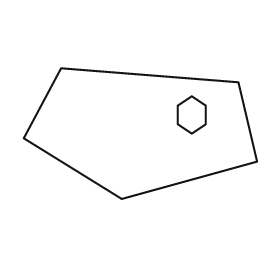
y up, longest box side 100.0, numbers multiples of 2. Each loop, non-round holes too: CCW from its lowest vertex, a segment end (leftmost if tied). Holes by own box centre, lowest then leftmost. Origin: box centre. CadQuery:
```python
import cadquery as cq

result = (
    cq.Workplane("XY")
    .moveTo(-8.0, -28.0)
    .lineTo(50.0, -12.0)
    .lineTo(42.0, 22.0)
    .lineTo(-34.0, 28.0)
    .lineTo(-50.0, -2.0)
    .close()
    .moveTo(22.0, 0.0)
    .lineTo(28.0, 4.0)
    .lineTo(28.0, 12.0)
    .lineTo(22.0, 16.0)
    .lineTo(16.0, 12.0)
    .lineTo(16.0, 4.0)
    .close()
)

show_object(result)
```